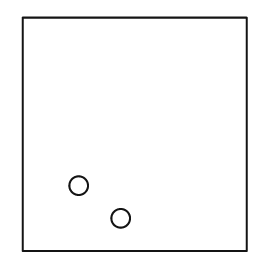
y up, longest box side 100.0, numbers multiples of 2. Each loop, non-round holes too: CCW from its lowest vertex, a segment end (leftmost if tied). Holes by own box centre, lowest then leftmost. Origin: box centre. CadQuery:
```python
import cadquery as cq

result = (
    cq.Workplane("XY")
    .moveTo(-48.0, -50.0)
    .lineTo(48.0, -50.0)
    .lineTo(48.0, 50.0)
    .lineTo(-48.0, 50.0)
    .close()
    .moveTo(-6.0, -36.0)
    .circle(4.0)
    .moveTo(-24.0, -22.0)
    .circle(4.0)
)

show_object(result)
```